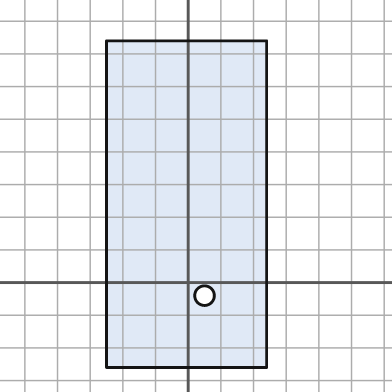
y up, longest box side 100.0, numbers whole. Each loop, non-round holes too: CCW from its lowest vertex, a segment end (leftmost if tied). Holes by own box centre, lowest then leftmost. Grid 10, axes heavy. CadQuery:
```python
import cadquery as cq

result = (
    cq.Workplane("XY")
    .moveTo(-25.0, -26.0)
    .lineTo(24.0, -26.0)
    .lineTo(24.0, 74.0)
    .lineTo(-25.0, 74.0)
    .close()
    .moveTo(5.0, -4.0)
    .circle(3.0)
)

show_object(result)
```